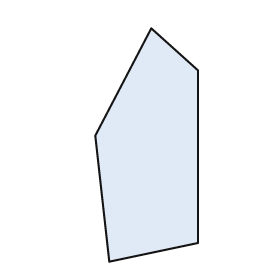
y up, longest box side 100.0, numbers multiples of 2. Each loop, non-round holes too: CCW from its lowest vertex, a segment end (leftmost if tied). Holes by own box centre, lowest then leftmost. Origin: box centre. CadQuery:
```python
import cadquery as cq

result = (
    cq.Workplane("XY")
    .moveTo(-16.0, -50.0)
    .lineTo(22.0, -42.0)
    .lineTo(22.0, 32.0)
    .lineTo(2.0, 50.0)
    .lineTo(-22.0, 4.0)
    .close()
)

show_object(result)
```